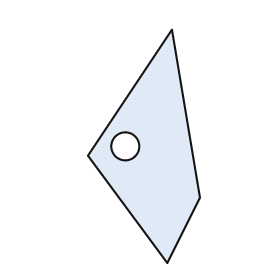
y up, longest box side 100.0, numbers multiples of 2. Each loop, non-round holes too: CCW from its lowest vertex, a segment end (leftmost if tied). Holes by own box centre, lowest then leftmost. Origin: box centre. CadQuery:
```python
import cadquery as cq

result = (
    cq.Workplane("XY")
    .moveTo(10.0, -50.0)
    .lineTo(24.0, -22.0)
    .lineTo(12.0, 50.0)
    .lineTo(-24.0, -4.0)
    .close()
    .moveTo(-8.0, 0.0)
    .circle(6.0)
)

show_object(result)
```